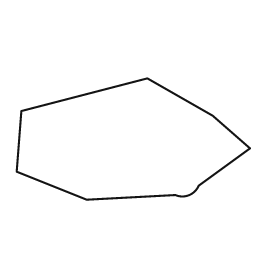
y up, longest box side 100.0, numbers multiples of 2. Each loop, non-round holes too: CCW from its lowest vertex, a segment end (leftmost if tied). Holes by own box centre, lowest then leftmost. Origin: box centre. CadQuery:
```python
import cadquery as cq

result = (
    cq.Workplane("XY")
    .moveTo(-20.0, -26.0)
    .lineTo(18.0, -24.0)
    .threePointArc((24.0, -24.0), (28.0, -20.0))
    .lineTo(50.0, -4.0)
    .lineTo(34.0, 10.0)
    .lineTo(6.0, 26.0)
    .lineTo(-48.0, 12.0)
    .lineTo(-50.0, -14.0)
    .close()
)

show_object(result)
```